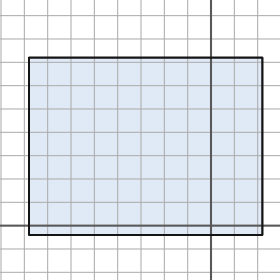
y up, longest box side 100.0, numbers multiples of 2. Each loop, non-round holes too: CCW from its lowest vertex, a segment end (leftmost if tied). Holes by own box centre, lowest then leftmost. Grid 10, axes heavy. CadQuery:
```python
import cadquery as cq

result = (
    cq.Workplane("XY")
    .moveTo(-78.0, -4.0)
    .lineTo(22.0, -4.0)
    .lineTo(22.0, 72.0)
    .lineTo(-78.0, 72.0)
    .close()
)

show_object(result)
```